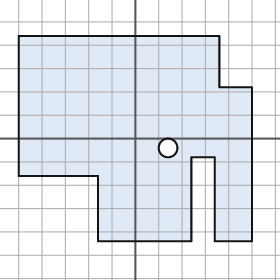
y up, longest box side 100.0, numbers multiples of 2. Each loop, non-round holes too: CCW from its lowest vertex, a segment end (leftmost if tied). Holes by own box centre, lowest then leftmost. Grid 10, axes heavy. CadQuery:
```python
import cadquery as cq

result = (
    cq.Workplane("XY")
    .moveTo(-16.0, -44.0)
    .lineTo(24.0, -44.0)
    .lineTo(24.0, -8.0)
    .lineTo(34.0, -8.0)
    .lineTo(34.0, -44.0)
    .lineTo(50.0, -44.0)
    .lineTo(50.0, 22.0)
    .lineTo(36.0, 22.0)
    .lineTo(36.0, 44.0)
    .lineTo(-50.0, 44.0)
    .lineTo(-50.0, -16.0)
    .lineTo(-16.0, -16.0)
    .close()
    .moveTo(14.0, -4.0)
    .circle(4.0)
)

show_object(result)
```